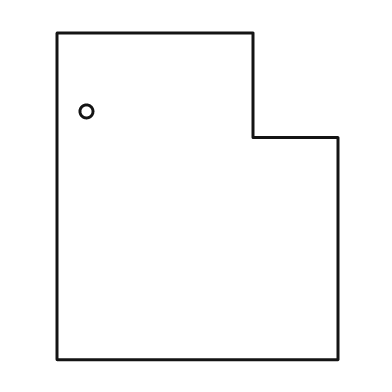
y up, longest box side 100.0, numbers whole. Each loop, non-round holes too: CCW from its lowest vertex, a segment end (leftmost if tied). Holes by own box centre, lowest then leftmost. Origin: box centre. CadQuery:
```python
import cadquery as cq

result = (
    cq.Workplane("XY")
    .moveTo(-43.0, -50.0)
    .lineTo(43.0, -50.0)
    .lineTo(43.0, 18.0)
    .lineTo(17.0, 18.0)
    .lineTo(17.0, 50.0)
    .lineTo(-43.0, 50.0)
    .close()
    .moveTo(-34.0, 26.0)
    .circle(2.0)
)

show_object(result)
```